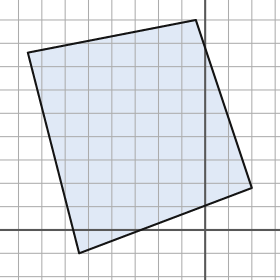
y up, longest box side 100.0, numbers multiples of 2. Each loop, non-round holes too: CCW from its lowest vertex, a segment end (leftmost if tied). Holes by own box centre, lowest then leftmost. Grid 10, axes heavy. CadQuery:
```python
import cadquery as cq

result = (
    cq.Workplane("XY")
    .moveTo(-54.0, -10.0)
    .lineTo(20.0, 18.0)
    .lineTo(-4.0, 90.0)
    .lineTo(-76.0, 76.0)
    .close()
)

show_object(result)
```